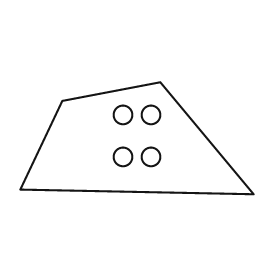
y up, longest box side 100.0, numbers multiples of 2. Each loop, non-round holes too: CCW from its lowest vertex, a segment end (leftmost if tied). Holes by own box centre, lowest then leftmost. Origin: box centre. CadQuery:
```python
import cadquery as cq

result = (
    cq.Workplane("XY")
    .moveTo(50.0, -24.0)
    .lineTo(10.0, 24.0)
    .lineTo(-32.0, 16.0)
    .lineTo(-50.0, -22.0)
    .close()
    .moveTo(-6.0, -8.0)
    .circle(4.0)
    .moveTo(6.0, -8.0)
    .circle(4.0)
    .moveTo(-6.0, 10.0)
    .circle(4.0)
    .moveTo(6.0, 10.0)
    .circle(4.0)
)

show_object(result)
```